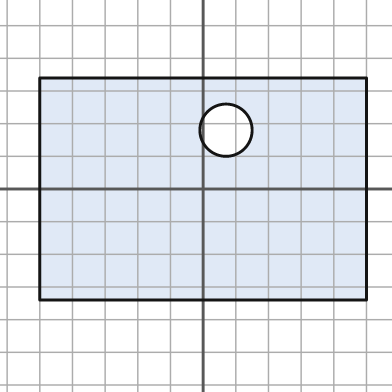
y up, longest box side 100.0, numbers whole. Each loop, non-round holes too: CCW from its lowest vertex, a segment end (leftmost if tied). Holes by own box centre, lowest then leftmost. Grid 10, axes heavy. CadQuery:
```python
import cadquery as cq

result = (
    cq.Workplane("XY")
    .moveTo(-50.0, -34.0)
    .lineTo(50.0, -34.0)
    .lineTo(50.0, 34.0)
    .lineTo(-50.0, 34.0)
    .close()
    .moveTo(7.0, 18.0)
    .circle(8.0)
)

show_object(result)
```